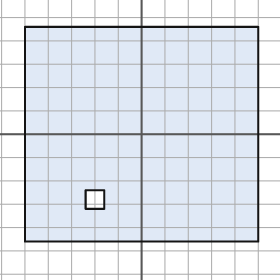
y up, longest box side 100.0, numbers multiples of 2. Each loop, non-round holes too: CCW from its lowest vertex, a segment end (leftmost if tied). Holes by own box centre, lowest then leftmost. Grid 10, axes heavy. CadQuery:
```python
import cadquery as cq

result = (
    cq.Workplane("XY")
    .moveTo(-50.0, -46.0)
    .lineTo(50.0, -46.0)
    .lineTo(50.0, 46.0)
    .lineTo(-50.0, 46.0)
    .close()
    .moveTo(-24.0, -32.0)
    .lineTo(-16.0, -32.0)
    .lineTo(-16.0, -24.0)
    .lineTo(-24.0, -24.0)
    .close()
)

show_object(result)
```